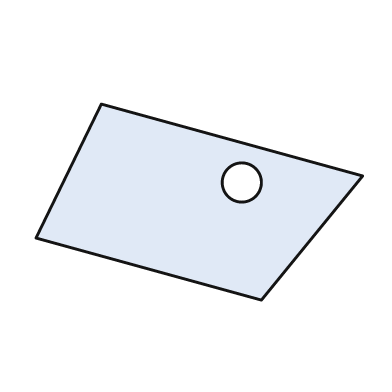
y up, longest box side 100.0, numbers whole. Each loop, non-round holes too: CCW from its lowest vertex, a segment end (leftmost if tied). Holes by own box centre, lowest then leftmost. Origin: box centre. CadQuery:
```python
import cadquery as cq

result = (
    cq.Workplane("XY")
    .moveTo(19.0, -30.0)
    .lineTo(50.0, 8.0)
    .lineTo(-30.0, 30.0)
    .lineTo(-50.0, -11.0)
    .close()
    .moveTo(13.0, 6.0)
    .circle(6.0)
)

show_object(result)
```